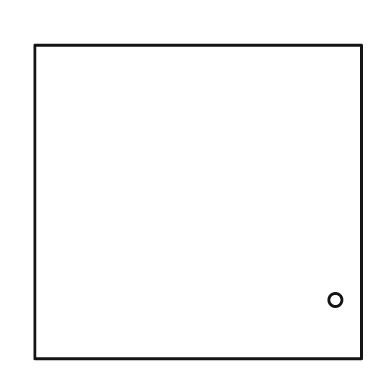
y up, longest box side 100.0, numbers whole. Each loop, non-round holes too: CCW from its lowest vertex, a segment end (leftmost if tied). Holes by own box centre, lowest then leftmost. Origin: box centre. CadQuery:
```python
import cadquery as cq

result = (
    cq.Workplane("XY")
    .moveTo(-50.0, -48.0)
    .lineTo(50.0, -48.0)
    .lineTo(50.0, 48.0)
    .lineTo(-50.0, 48.0)
    .close()
    .moveTo(42.0, -30.0)
    .circle(2.0)
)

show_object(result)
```